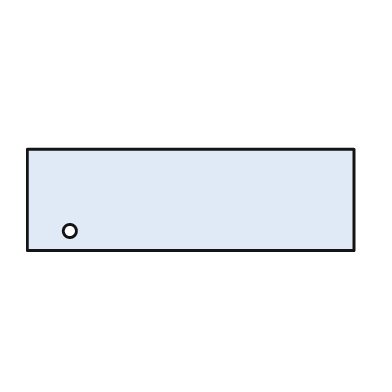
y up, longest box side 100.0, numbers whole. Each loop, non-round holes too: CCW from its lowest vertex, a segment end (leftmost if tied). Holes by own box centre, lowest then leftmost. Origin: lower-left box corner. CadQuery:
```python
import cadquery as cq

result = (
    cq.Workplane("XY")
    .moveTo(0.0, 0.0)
    .lineTo(100.0, 0.0)
    .lineTo(100.0, 31.0)
    .lineTo(0.0, 31.0)
    .close()
    .moveTo(13.0, 6.0)
    .circle(2.0)
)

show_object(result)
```